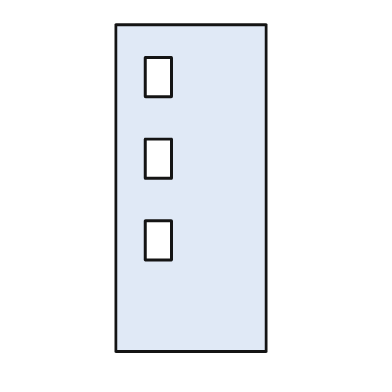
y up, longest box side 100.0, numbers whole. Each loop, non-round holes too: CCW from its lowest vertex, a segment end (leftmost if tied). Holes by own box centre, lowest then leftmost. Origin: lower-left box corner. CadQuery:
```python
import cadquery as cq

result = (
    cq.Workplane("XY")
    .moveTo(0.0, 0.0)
    .lineTo(46.0, 0.0)
    .lineTo(46.0, 100.0)
    .lineTo(0.0, 100.0)
    .close()
    .moveTo(9.0, 28.0)
    .lineTo(17.0, 28.0)
    .lineTo(17.0, 40.0)
    .lineTo(9.0, 40.0)
    .close()
    .moveTo(9.0, 53.0)
    .lineTo(17.0, 53.0)
    .lineTo(17.0, 65.0)
    .lineTo(9.0, 65.0)
    .close()
    .moveTo(9.0, 78.0)
    .lineTo(17.0, 78.0)
    .lineTo(17.0, 90.0)
    .lineTo(9.0, 90.0)
    .close()
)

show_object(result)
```